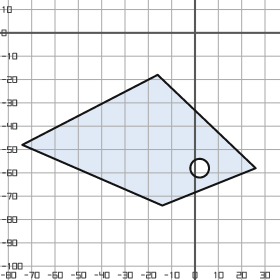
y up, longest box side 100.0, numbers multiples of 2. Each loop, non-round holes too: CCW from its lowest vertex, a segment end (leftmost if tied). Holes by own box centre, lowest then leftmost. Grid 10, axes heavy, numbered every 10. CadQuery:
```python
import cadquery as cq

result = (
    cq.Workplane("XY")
    .moveTo(-14.0, -74.0)
    .lineTo(26.0, -58.0)
    .lineTo(-16.0, -18.0)
    .lineTo(-74.0, -48.0)
    .close()
    .moveTo(2.0, -58.0)
    .circle(4.0)
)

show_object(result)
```